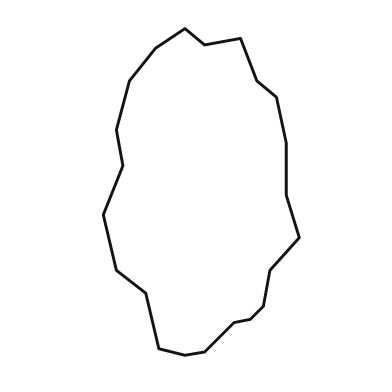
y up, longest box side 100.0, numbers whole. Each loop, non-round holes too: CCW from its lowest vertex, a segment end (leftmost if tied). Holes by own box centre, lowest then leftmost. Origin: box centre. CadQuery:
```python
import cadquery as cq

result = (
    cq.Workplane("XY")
    .moveTo(-5.0, -50.0)
    .lineTo(1.0, -49.0)
    .lineTo(10.0, -40.0)
    .lineTo(15.0, -39.0)
    .lineTo(19.0, -35.0)
    .lineTo(21.0, -24.0)
    .lineTo(30.0, -14.0)
    .lineTo(26.0, -1.0)
    .lineTo(26.0, 15.0)
    .lineTo(23.0, 29.0)
    .lineTo(17.0, 34.0)
    .lineTo(12.0, 47.0)
    .lineTo(1.0, 45.0)
    .lineTo(-5.0, 50.0)
    .lineTo(-14.0, 44.0)
    .lineTo(-22.0, 34.0)
    .lineTo(-26.0, 19.0)
    .lineTo(-24.0, 8.0)
    .lineTo(-30.0, -7.0)
    .lineTo(-26.0, -24.0)
    .lineTo(-17.0, -31.0)
    .lineTo(-13.0, -48.0)
    .close()
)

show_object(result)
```